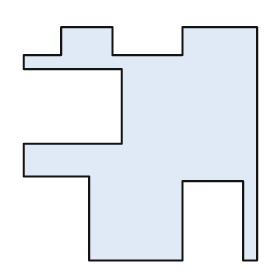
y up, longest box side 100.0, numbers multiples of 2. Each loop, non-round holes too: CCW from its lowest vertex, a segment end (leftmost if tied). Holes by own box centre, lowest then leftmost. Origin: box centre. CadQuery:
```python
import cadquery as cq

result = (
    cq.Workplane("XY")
    .moveTo(-22.0, -50.0)
    .lineTo(18.0, -50.0)
    .lineTo(18.0, -16.0)
    .lineTo(44.0, -16.0)
    .lineTo(44.0, -50.0)
    .lineTo(50.0, -50.0)
    .lineTo(50.0, 50.0)
    .lineTo(18.0, 50.0)
    .lineTo(18.0, 38.0)
    .lineTo(-12.0, 38.0)
    .lineTo(-12.0, 50.0)
    .lineTo(-34.0, 50.0)
    .lineTo(-34.0, 38.0)
    .lineTo(-50.0, 38.0)
    .lineTo(-50.0, 32.0)
    .lineTo(-8.0, 32.0)
    .lineTo(-8.0, 0.0)
    .lineTo(-50.0, 0.0)
    .lineTo(-50.0, -14.0)
    .lineTo(-22.0, -14.0)
    .close()
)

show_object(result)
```